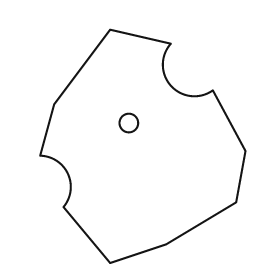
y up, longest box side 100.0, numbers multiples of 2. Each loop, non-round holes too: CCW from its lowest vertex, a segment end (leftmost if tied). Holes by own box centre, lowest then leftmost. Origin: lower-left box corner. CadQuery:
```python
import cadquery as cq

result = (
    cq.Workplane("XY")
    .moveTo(30.0, 0.0)
    .lineTo(54.0, 8.0)
    .lineTo(84.0, 26.0)
    .lineTo(88.0, 48.0)
    .lineTo(74.0, 74.0)
    .threePointArc((56.0, 76.0), (56.0, 94.0))
    .lineTo(30.0, 100.0)
    .lineTo(6.0, 68.0)
    .lineTo(0.0, 46.0)
    .threePointArc((12.0, 38.0), (10.0, 24.0))
    .close()
    .moveTo(38.0, 60.0)
    .circle(4.0)
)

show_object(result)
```